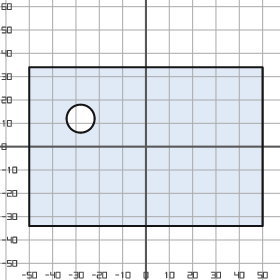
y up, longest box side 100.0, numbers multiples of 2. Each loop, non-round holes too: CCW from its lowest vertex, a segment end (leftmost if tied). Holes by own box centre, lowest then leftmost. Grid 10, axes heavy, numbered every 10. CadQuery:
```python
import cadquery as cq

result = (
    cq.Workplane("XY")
    .moveTo(-50.0, -34.0)
    .lineTo(50.0, -34.0)
    .lineTo(50.0, 34.0)
    .lineTo(-50.0, 34.0)
    .close()
    .moveTo(-28.0, 12.0)
    .circle(6.0)
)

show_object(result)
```